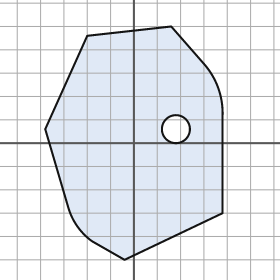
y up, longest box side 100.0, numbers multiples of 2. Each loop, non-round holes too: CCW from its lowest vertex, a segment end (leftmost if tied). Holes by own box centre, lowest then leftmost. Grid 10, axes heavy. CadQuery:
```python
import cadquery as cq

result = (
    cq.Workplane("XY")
    .moveTo(-4.0, -50.0)
    .lineTo(38.0, -30.0)
    .lineTo(38.0, 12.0)
    .threePointArc((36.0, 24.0), (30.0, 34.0))
    .lineTo(16.0, 50.0)
    .lineTo(-20.0, 46.0)
    .lineTo(-38.0, 6.0)
    .lineTo(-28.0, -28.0)
    .threePointArc((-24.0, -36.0), (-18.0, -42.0))
    .close()
    .moveTo(18.0, 6.0)
    .circle(6.0)
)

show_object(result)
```